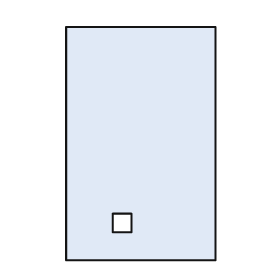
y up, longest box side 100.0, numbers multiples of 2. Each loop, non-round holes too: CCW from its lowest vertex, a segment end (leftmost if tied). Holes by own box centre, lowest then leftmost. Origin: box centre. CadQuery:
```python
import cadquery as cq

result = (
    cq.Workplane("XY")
    .moveTo(-32.0, -50.0)
    .lineTo(32.0, -50.0)
    .lineTo(32.0, 50.0)
    .lineTo(-32.0, 50.0)
    .close()
    .moveTo(-12.0, -38.0)
    .lineTo(-4.0, -38.0)
    .lineTo(-4.0, -30.0)
    .lineTo(-12.0, -30.0)
    .close()
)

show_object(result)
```